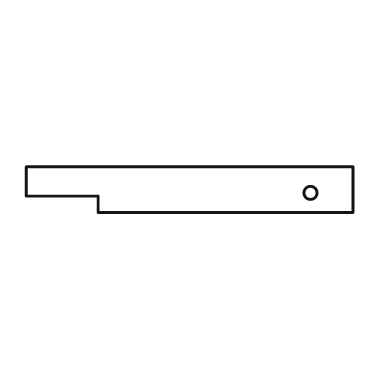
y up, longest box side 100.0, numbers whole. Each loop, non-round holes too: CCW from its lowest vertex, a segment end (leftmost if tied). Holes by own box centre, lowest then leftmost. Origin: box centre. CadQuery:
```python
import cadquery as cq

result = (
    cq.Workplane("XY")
    .moveTo(-28.0, -7.0)
    .lineTo(50.0, -7.0)
    .lineTo(50.0, 7.0)
    .lineTo(-50.0, 7.0)
    .lineTo(-50.0, -2.0)
    .lineTo(-28.0, -2.0)
    .close()
    .moveTo(37.0, -1.0)
    .circle(2.0)
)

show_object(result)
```